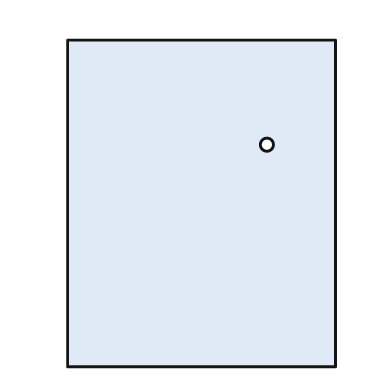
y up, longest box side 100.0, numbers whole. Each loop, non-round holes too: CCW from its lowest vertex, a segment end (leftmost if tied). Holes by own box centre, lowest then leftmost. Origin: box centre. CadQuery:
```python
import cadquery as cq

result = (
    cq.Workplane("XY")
    .moveTo(-41.0, -50.0)
    .lineTo(41.0, -50.0)
    .lineTo(41.0, 50.0)
    .lineTo(-41.0, 50.0)
    .close()
    .moveTo(20.0, 18.0)
    .circle(2.0)
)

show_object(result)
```